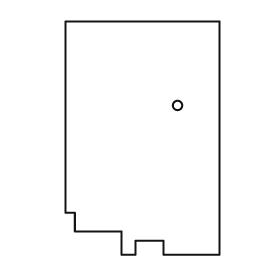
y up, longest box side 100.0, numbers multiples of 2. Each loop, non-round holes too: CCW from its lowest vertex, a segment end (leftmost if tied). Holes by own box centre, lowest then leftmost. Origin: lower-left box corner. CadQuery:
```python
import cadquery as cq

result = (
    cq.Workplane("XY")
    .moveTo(24.0, 0.0)
    .lineTo(30.0, 0.0)
    .lineTo(30.0, 6.0)
    .lineTo(42.0, 6.0)
    .lineTo(42.0, 0.0)
    .lineTo(66.0, 0.0)
    .lineTo(66.0, 100.0)
    .lineTo(0.0, 100.0)
    .lineTo(0.0, 18.0)
    .lineTo(4.0, 18.0)
    .lineTo(4.0, 10.0)
    .lineTo(24.0, 10.0)
    .close()
    .moveTo(48.0, 64.0)
    .circle(2.0)
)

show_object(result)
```